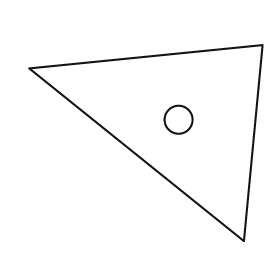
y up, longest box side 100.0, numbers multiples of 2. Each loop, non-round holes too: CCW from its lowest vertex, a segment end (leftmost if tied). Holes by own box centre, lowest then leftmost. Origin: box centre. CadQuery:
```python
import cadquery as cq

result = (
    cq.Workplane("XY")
    .moveTo(42.0, -42.0)
    .lineTo(50.0, 42.0)
    .lineTo(-50.0, 32.0)
    .close()
    .moveTo(14.0, 10.0)
    .circle(6.0)
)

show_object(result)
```